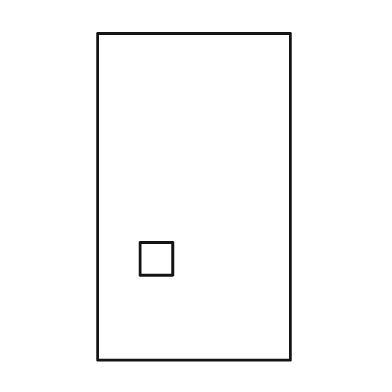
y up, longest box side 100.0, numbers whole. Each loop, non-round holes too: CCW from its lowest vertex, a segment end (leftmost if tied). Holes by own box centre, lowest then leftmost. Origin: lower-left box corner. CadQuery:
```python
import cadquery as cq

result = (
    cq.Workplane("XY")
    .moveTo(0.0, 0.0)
    .lineTo(59.0, 0.0)
    .lineTo(59.0, 100.0)
    .lineTo(0.0, 100.0)
    .close()
    .moveTo(13.0, 26.0)
    .lineTo(23.0, 26.0)
    .lineTo(23.0, 36.0)
    .lineTo(13.0, 36.0)
    .close()
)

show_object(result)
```